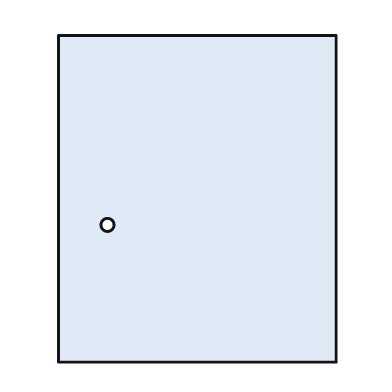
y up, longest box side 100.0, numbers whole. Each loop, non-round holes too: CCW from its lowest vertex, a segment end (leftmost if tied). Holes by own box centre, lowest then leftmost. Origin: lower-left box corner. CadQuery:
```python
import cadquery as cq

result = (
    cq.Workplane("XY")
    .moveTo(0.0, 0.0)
    .lineTo(85.0, 0.0)
    .lineTo(85.0, 100.0)
    .lineTo(0.0, 100.0)
    .close()
    .moveTo(15.0, 42.0)
    .circle(2.0)
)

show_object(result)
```